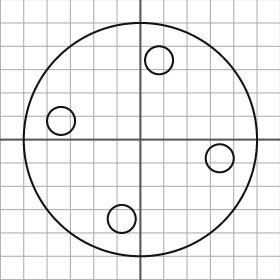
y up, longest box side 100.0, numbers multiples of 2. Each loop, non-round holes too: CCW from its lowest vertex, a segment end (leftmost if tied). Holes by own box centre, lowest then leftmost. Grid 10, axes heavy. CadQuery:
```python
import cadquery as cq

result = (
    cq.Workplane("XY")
    .moveTo(0.0, 0.0)
    .circle(50.0)
    .moveTo(-8.0, -34.0)
    .circle(6.0)
    .moveTo(34.0, -8.0)
    .circle(6.0)
    .moveTo(-34.0, 8.0)
    .circle(6.0)
    .moveTo(8.0, 34.0)
    .circle(6.0)
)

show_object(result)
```